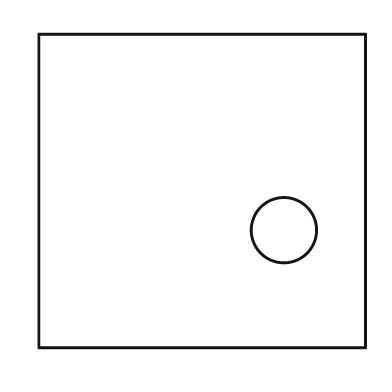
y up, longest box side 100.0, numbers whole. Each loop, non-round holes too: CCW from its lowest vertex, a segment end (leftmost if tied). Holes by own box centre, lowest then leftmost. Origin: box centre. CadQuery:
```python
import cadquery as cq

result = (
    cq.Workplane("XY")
    .moveTo(-50.0, -48.0)
    .lineTo(50.0, -48.0)
    .lineTo(50.0, 48.0)
    .lineTo(-50.0, 48.0)
    .close()
    .moveTo(25.0, -12.0)
    .circle(10.0)
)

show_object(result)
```